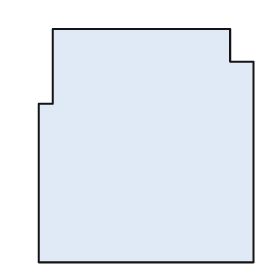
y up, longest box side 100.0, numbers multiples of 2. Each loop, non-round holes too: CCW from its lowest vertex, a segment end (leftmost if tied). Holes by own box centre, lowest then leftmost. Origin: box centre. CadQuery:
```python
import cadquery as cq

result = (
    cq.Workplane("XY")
    .moveTo(-46.0, -50.0)
    .lineTo(46.0, -50.0)
    .lineTo(46.0, 36.0)
    .lineTo(36.0, 36.0)
    .lineTo(36.0, 50.0)
    .lineTo(-40.0, 50.0)
    .lineTo(-40.0, 18.0)
    .lineTo(-46.0, 18.0)
    .close()
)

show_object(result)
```